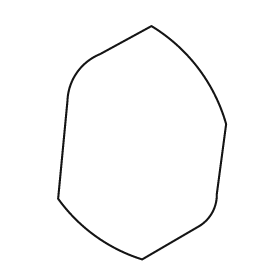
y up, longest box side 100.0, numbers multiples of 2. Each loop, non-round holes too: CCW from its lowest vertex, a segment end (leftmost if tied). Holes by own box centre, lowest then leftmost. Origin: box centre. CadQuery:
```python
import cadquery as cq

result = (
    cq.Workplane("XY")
    .moveTo(0.0, -50.0)
    .lineTo(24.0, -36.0)
    .threePointArc((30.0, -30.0), (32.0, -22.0))
    .lineTo(36.0, 8.0)
    .threePointArc((24.0, 32.0), (4.0, 50.0))
    .lineTo(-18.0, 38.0)
    .threePointArc((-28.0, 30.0), (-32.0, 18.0))
    .lineTo(-36.0, -24.0)
    .threePointArc((-20.0, -40.0), (0.0, -50.0))
    .close()
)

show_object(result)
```